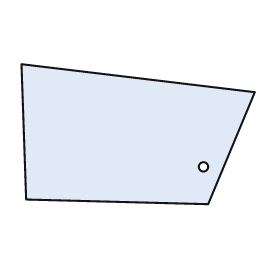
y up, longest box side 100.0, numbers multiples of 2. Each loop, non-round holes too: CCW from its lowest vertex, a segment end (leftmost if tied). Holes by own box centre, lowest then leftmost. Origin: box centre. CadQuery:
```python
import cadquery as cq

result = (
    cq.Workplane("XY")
    .moveTo(30.0, -30.0)
    .lineTo(50.0, 18.0)
    .lineTo(-50.0, 30.0)
    .lineTo(-48.0, -28.0)
    .close()
    .moveTo(28.0, -14.0)
    .circle(2.0)
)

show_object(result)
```